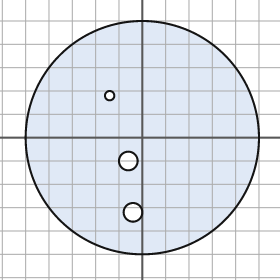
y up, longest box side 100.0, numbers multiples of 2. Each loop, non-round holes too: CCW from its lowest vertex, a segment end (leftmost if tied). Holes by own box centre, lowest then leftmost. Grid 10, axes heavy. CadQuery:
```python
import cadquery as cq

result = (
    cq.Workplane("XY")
    .moveTo(0.0, 0.0)
    .circle(50.0)
    .moveTo(-4.0, -32.0)
    .circle(4.0)
    .moveTo(-6.0, -10.0)
    .circle(4.0)
    .moveTo(-14.0, 18.0)
    .circle(2.0)
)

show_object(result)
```